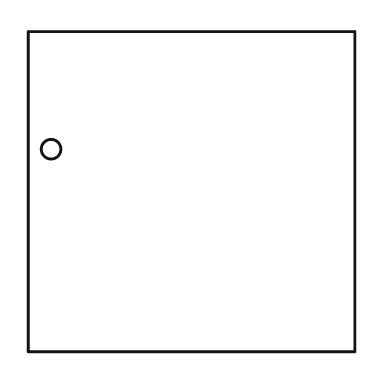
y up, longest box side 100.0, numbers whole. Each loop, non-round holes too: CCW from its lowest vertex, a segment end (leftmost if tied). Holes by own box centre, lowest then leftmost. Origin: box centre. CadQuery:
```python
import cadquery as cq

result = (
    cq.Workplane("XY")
    .moveTo(-50.0, -49.0)
    .lineTo(50.0, -49.0)
    .lineTo(50.0, 49.0)
    .lineTo(-50.0, 49.0)
    .close()
    .moveTo(-43.0, 13.0)
    .circle(3.0)
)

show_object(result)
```